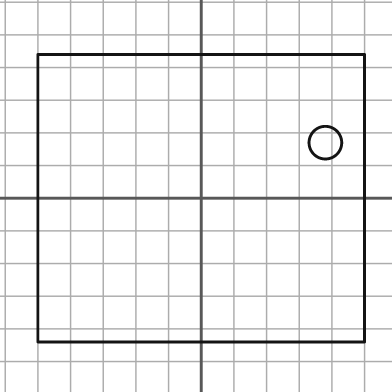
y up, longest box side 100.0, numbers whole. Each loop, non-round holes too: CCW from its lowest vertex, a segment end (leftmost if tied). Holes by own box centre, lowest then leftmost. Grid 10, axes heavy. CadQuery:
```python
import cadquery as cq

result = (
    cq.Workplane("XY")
    .moveTo(-50.0, -44.0)
    .lineTo(50.0, -44.0)
    .lineTo(50.0, 44.0)
    .lineTo(-50.0, 44.0)
    .close()
    .moveTo(38.0, 17.0)
    .circle(5.0)
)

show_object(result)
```